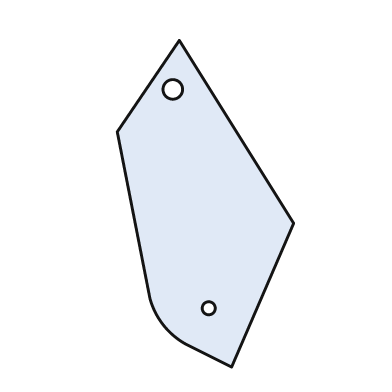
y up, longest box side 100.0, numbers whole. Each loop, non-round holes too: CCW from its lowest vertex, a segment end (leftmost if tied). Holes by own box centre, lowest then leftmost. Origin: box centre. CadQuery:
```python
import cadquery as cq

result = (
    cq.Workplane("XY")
    .moveTo(8.0, -50.0)
    .lineTo(27.0, -6.0)
    .lineTo(-8.0, 50.0)
    .lineTo(-27.0, 22.0)
    .lineTo(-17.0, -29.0)
    .threePointArc((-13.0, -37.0), (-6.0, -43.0))
    .close()
    .moveTo(1.0, -32.0)
    .circle(2.0)
    .moveTo(-10.0, 35.0)
    .circle(3.0)
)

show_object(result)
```